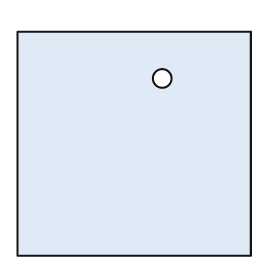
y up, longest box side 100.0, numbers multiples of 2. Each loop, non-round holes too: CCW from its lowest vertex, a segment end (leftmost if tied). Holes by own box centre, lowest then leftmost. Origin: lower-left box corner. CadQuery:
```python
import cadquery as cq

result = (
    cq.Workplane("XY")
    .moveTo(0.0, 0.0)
    .lineTo(100.0, 0.0)
    .lineTo(100.0, 96.0)
    .lineTo(0.0, 96.0)
    .close()
    .moveTo(62.0, 76.0)
    .circle(4.0)
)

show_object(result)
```